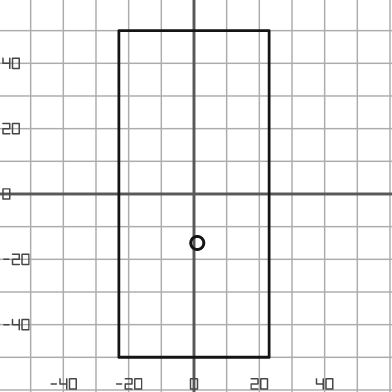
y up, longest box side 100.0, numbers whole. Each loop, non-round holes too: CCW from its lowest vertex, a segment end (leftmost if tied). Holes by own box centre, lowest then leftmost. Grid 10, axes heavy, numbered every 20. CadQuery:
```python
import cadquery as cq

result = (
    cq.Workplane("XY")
    .moveTo(-23.0, -50.0)
    .lineTo(23.0, -50.0)
    .lineTo(23.0, 50.0)
    .lineTo(-23.0, 50.0)
    .close()
    .moveTo(1.0, -15.0)
    .circle(2.0)
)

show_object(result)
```